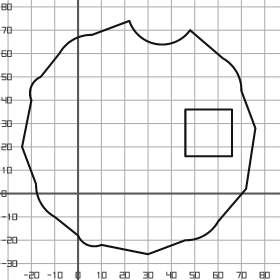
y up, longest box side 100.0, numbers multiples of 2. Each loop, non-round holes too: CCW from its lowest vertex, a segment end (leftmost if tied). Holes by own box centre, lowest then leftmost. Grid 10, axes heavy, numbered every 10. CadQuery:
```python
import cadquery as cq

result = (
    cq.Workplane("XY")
    .moveTo(30.0, -26.0)
    .lineTo(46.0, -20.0)
    .threePointArc((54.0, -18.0), (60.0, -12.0))
    .lineTo(72.0, 2.0)
    .lineTo(76.0, 28.0)
    .lineTo(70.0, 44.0)
    .threePointArc((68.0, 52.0), (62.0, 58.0))
    .lineTo(48.0, 70.0)
    .threePointArc((34.0, 64.0), (22.0, 74.0))
    .lineTo(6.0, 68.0)
    .threePointArc((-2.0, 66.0), (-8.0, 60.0))
    .lineTo(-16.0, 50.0)
    .threePointArc((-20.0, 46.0), (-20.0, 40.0))
    .lineTo(-24.0, 20.0)
    .lineTo(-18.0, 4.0)
    .threePointArc((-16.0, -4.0), (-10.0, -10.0))
    .lineTo(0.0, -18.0)
    .threePointArc((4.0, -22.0), (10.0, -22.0))
    .close()
    .moveTo(46.0, 16.0)
    .lineTo(66.0, 16.0)
    .lineTo(66.0, 36.0)
    .lineTo(46.0, 36.0)
    .close()
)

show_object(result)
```